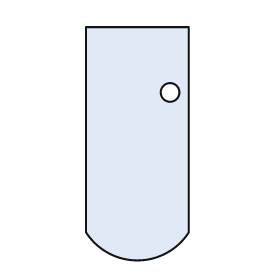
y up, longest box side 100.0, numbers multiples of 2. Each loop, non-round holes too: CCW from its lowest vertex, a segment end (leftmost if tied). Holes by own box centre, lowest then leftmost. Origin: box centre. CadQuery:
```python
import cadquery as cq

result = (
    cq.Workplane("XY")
    .moveTo(-22.0, -38.0)
    .threePointArc((0.0, -50.0), (22.0, -38.0))
    .lineTo(22.0, 50.0)
    .lineTo(-22.0, 50.0)
    .close()
    .moveTo(14.0, 22.0)
    .circle(4.0)
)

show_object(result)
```